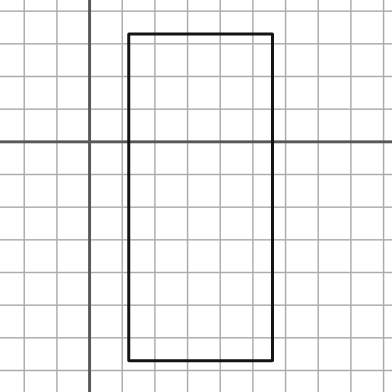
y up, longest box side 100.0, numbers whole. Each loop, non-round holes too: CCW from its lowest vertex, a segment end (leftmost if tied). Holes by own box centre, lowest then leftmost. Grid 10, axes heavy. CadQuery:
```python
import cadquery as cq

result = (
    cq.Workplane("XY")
    .moveTo(12.0, -67.0)
    .lineTo(56.0, -67.0)
    .lineTo(56.0, 33.0)
    .lineTo(12.0, 33.0)
    .close()
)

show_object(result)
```